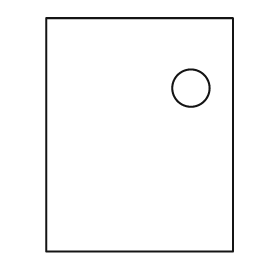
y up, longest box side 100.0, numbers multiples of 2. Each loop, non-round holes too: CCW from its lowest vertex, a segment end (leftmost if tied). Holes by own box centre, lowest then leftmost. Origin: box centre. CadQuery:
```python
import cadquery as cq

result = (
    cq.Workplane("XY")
    .moveTo(-40.0, -50.0)
    .lineTo(40.0, -50.0)
    .lineTo(40.0, 50.0)
    .lineTo(-40.0, 50.0)
    .close()
    .moveTo(22.0, 20.0)
    .circle(8.0)
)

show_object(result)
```